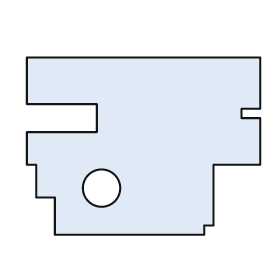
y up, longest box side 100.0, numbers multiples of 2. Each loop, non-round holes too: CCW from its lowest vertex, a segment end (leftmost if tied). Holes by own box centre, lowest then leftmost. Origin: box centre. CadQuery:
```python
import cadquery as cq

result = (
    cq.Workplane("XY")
    .moveTo(-38.0, -38.0)
    .lineTo(26.0, -38.0)
    .lineTo(26.0, -34.0)
    .lineTo(30.0, -34.0)
    .lineTo(30.0, -8.0)
    .lineTo(50.0, -8.0)
    .lineTo(50.0, 12.0)
    .lineTo(42.0, 12.0)
    .lineTo(42.0, 16.0)
    .lineTo(50.0, 16.0)
    .lineTo(50.0, 38.0)
    .lineTo(-50.0, 38.0)
    .lineTo(-50.0, 18.0)
    .lineTo(-20.0, 18.0)
    .lineTo(-20.0, 6.0)
    .lineTo(-50.0, 6.0)
    .lineTo(-50.0, -8.0)
    .lineTo(-46.0, -8.0)
    .lineTo(-46.0, -22.0)
    .lineTo(-38.0, -22.0)
    .close()
    .moveTo(-18.0, -18.0)
    .circle(8.0)
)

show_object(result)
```